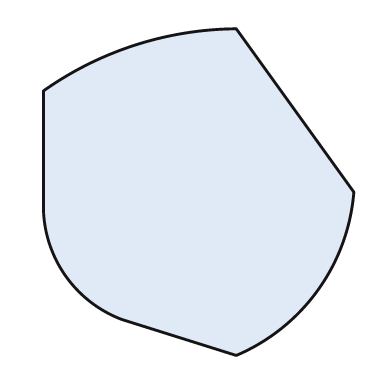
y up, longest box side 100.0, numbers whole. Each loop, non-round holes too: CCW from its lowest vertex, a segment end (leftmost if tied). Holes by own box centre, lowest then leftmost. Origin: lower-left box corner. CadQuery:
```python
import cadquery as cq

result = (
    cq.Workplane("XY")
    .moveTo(59.0, 0.0)
    .threePointArc((84.0, 20.0), (95.0, 50.0))
    .lineTo(59.0, 100.0)
    .threePointArc((28.0, 95.0), (0.0, 81.0))
    .lineTo(0.0, 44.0)
    .threePointArc((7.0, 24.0), (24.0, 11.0))
    .close()
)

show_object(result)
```